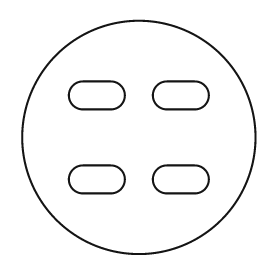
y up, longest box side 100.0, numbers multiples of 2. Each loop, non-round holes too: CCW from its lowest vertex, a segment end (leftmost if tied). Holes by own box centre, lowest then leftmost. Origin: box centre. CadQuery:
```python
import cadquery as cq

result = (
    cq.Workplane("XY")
    .moveTo(0.0, 0.0)
    .circle(50.0)
    .moveTo(-24.0, -24.0)
    .lineTo(-12.0, -24.0)
    .threePointArc((-6.0, -18.0), (-12.0, -12.0))
    .lineTo(-24.0, -12.0)
    .threePointArc((-30.0, -18.0), (-24.0, -24.0))
    .close()
    .moveTo(12.0, -24.0)
    .lineTo(24.0, -24.0)
    .threePointArc((30.0, -18.0), (24.0, -12.0))
    .lineTo(12.0, -12.0)
    .threePointArc((6.0, -18.0), (12.0, -24.0))
    .close()
    .moveTo(-24.0, 12.0)
    .lineTo(-12.0, 12.0)
    .threePointArc((-6.0, 18.0), (-12.0, 24.0))
    .lineTo(-24.0, 24.0)
    .threePointArc((-30.0, 18.0), (-24.0, 12.0))
    .close()
    .moveTo(12.0, 12.0)
    .lineTo(24.0, 12.0)
    .threePointArc((30.0, 18.0), (24.0, 24.0))
    .lineTo(12.0, 24.0)
    .threePointArc((6.0, 18.0), (12.0, 12.0))
    .close()
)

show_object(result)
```